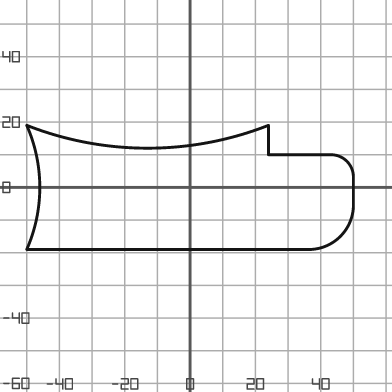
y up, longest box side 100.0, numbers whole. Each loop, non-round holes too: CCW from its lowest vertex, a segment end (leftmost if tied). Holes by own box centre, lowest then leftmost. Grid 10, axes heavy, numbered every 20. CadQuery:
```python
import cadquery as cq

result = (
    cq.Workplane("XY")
    .moveTo(-50.0, -19.0)
    .lineTo(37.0, -19.0)
    .threePointArc((46.0, -15.0), (50.0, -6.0))
    .lineTo(50.0, 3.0)
    .threePointArc((48.0, 8.0), (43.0, 10.0))
    .lineTo(24.0, 10.0)
    .lineTo(24.0, 19.0)
    .threePointArc((-13.0, 12.0), (-50.0, 19.0))
    .threePointArc((-46.0, 0.0), (-50.0, -19.0))
    .close()
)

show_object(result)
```